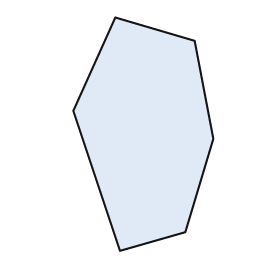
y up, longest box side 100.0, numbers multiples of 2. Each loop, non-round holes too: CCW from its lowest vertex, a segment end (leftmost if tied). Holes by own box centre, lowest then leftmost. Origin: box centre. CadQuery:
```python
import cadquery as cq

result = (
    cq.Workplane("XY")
    .moveTo(-10.0, -50.0)
    .lineTo(18.0, -42.0)
    .lineTo(30.0, -2.0)
    .lineTo(22.0, 40.0)
    .lineTo(-12.0, 50.0)
    .lineTo(-30.0, 10.0)
    .close()
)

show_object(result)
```